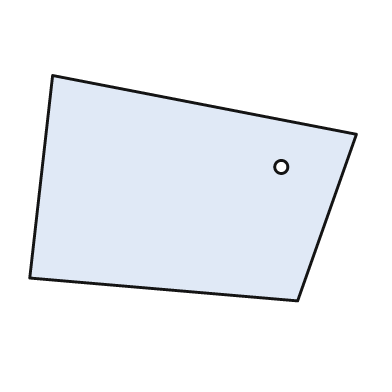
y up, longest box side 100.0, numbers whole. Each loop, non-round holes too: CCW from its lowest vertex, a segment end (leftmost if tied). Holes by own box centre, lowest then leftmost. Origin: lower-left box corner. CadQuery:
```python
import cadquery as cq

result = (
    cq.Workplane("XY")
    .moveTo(82.0, 0.0)
    .lineTo(100.0, 51.0)
    .lineTo(7.0, 69.0)
    .lineTo(0.0, 7.0)
    .close()
    .moveTo(77.0, 41.0)
    .circle(2.0)
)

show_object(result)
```